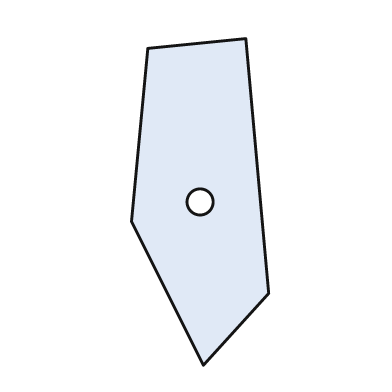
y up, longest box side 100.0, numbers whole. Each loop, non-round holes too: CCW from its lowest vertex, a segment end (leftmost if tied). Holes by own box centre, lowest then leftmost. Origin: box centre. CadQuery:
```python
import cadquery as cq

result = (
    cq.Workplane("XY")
    .moveTo(1.0, -50.0)
    .lineTo(21.0, -28.0)
    .lineTo(14.0, 50.0)
    .lineTo(-16.0, 47.0)
    .lineTo(-21.0, -6.0)
    .close()
    .moveTo(0.0, 0.0)
    .circle(4.0)
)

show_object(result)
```